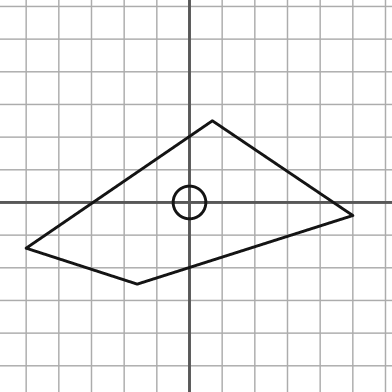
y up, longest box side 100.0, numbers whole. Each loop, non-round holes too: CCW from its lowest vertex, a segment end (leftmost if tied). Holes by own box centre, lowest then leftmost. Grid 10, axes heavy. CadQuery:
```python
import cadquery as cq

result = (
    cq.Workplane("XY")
    .moveTo(-16.0, -25.0)
    .lineTo(50.0, -4.0)
    .lineTo(7.0, 25.0)
    .lineTo(-50.0, -14.0)
    .close()
    .moveTo(0.0, 0.0)
    .circle(5.0)
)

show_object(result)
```